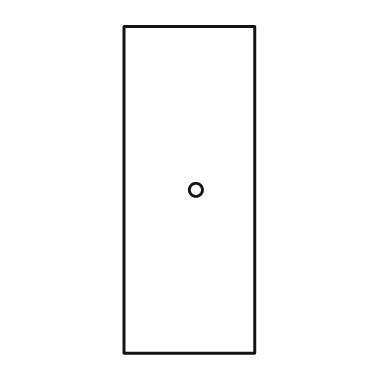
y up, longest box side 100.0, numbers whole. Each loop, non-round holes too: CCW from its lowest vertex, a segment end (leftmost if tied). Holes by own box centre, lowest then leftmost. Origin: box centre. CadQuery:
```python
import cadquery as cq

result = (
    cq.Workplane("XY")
    .moveTo(-20.0, -50.0)
    .lineTo(20.0, -50.0)
    .lineTo(20.0, 50.0)
    .lineTo(-20.0, 50.0)
    .close()
    .moveTo(2.0, 0.0)
    .circle(2.0)
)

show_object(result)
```